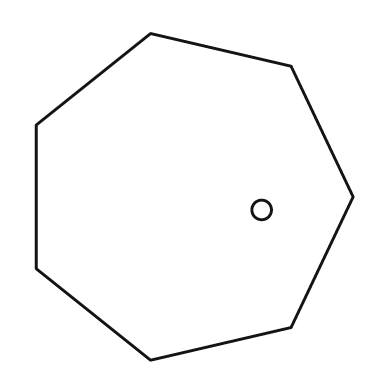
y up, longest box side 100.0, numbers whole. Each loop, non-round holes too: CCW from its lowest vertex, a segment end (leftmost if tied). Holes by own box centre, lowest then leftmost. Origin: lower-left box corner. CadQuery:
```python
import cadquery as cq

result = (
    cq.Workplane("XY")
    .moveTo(35.0, 0.0)
    .lineTo(78.0, 10.0)
    .lineTo(97.0, 50.0)
    .lineTo(78.0, 90.0)
    .lineTo(35.0, 100.0)
    .lineTo(0.0, 72.0)
    .lineTo(0.0, 28.0)
    .close()
    .moveTo(69.0, 46.0)
    .circle(3.0)
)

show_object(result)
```